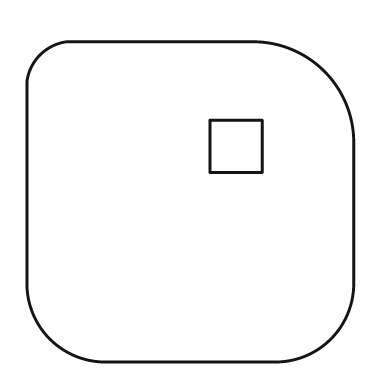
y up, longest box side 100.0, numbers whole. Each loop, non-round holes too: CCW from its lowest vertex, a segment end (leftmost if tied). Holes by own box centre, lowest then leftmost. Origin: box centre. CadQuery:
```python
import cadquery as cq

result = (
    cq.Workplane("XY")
    .moveTo(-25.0, -49.0)
    .lineTo(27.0, -49.0)
    .threePointArc((43.0, -42.0), (50.0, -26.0))
    .lineTo(50.0, 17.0)
    .threePointArc((41.0, 40.0), (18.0, 49.0))
    .lineTo(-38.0, 49.0)
    .threePointArc((-46.0, 45.0), (-50.0, 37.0))
    .lineTo(-50.0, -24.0)
    .threePointArc((-43.0, -42.0), (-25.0, -49.0))
    .close()
    .moveTo(6.0, 9.0)
    .lineTo(22.0, 9.0)
    .lineTo(22.0, 25.0)
    .lineTo(6.0, 25.0)
    .close()
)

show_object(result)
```